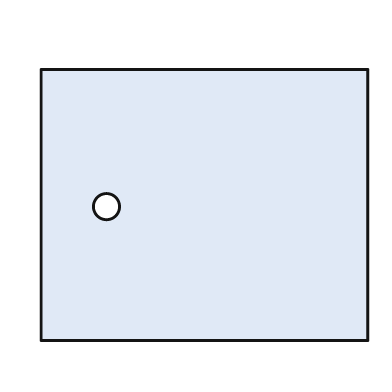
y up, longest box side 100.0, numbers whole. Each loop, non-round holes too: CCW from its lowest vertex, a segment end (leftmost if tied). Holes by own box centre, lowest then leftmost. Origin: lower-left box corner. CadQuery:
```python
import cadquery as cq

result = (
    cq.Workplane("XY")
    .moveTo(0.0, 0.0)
    .lineTo(100.0, 0.0)
    .lineTo(100.0, 83.0)
    .lineTo(0.0, 83.0)
    .close()
    .moveTo(20.0, 41.0)
    .circle(4.0)
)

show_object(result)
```